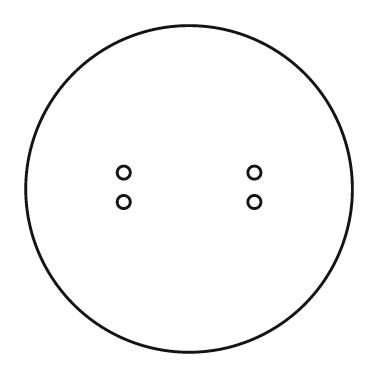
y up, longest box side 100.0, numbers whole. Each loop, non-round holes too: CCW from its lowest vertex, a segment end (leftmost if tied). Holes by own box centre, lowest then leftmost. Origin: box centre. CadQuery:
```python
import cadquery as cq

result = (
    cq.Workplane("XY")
    .moveTo(0.0, 0.0)
    .circle(50.0)
    .moveTo(-20.0, -4.0)
    .circle(2.0)
    .moveTo(20.0, -4.0)
    .circle(2.0)
    .moveTo(-20.0, 5.0)
    .circle(2.0)
    .moveTo(20.0, 5.0)
    .circle(2.0)
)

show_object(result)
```